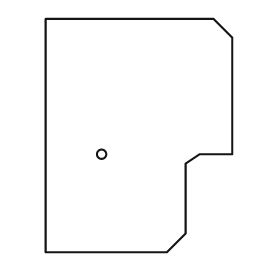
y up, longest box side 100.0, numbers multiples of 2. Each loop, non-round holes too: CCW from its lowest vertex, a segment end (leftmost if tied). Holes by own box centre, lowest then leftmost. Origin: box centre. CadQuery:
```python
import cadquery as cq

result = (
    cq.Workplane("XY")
    .moveTo(-40.0, -50.0)
    .lineTo(12.0, -50.0)
    .lineTo(20.0, -42.0)
    .lineTo(20.0, -12.0)
    .lineTo(26.0, -8.0)
    .lineTo(40.0, -8.0)
    .lineTo(40.0, 42.0)
    .lineTo(32.0, 50.0)
    .lineTo(-40.0, 50.0)
    .close()
    .moveTo(-16.0, -8.0)
    .circle(2.0)
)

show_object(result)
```